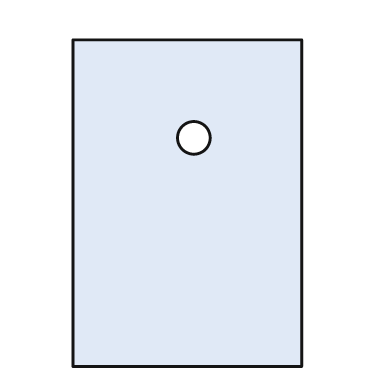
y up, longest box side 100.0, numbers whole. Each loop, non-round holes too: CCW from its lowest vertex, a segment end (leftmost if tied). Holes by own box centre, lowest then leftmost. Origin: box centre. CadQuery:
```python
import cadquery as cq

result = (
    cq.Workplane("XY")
    .moveTo(-35.0, -50.0)
    .lineTo(35.0, -50.0)
    .lineTo(35.0, 50.0)
    .lineTo(-35.0, 50.0)
    .close()
    .moveTo(2.0, 20.0)
    .circle(5.0)
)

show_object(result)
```